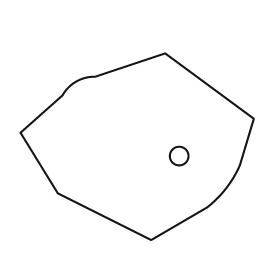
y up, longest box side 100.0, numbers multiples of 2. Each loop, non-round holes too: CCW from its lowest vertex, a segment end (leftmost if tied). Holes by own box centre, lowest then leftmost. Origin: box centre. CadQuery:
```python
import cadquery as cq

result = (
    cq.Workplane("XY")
    .moveTo(6.0, -40.0)
    .lineTo(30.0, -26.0)
    .threePointArc((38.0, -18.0), (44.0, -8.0))
    .lineTo(50.0, 12.0)
    .lineTo(12.0, 40.0)
    .lineTo(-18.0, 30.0)
    .threePointArc((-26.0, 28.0), (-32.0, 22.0))
    .lineTo(-50.0, 6.0)
    .lineTo(-34.0, -20.0)
    .close()
    .moveTo(18.0, -4.0)
    .circle(4.0)
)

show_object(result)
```